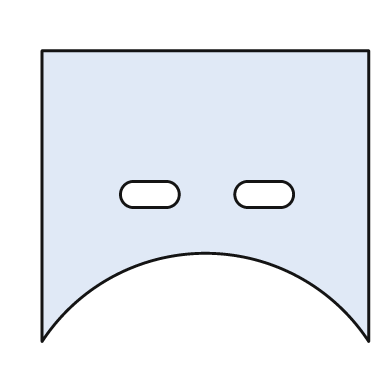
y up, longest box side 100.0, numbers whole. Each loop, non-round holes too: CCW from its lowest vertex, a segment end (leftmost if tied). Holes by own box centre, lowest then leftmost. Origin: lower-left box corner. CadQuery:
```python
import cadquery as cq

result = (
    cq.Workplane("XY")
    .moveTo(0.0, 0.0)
    .threePointArc((50.0, 27.0), (100.0, 0.0))
    .lineTo(100.0, 89.0)
    .lineTo(0.0, 89.0)
    .close()
    .moveTo(28.0, 41.0)
    .lineTo(38.0, 41.0)
    .threePointArc((42.0, 45.0), (38.0, 49.0))
    .lineTo(28.0, 49.0)
    .threePointArc((24.0, 45.0), (28.0, 41.0))
    .close()
    .moveTo(63.0, 41.0)
    .lineTo(73.0, 41.0)
    .threePointArc((77.0, 45.0), (73.0, 49.0))
    .lineTo(63.0, 49.0)
    .threePointArc((59.0, 45.0), (63.0, 41.0))
    .close()
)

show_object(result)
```